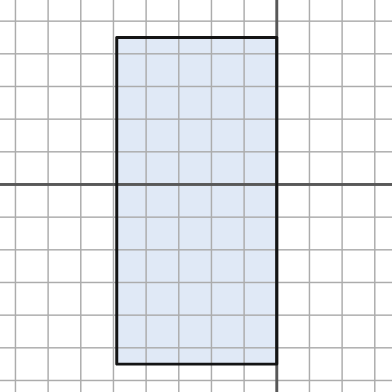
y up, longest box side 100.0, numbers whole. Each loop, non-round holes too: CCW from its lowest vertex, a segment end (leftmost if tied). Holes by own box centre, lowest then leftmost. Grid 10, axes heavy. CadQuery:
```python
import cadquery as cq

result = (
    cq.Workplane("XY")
    .moveTo(-49.0, -55.0)
    .lineTo(0.0, -55.0)
    .lineTo(0.0, 45.0)
    .lineTo(-49.0, 45.0)
    .close()
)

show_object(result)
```